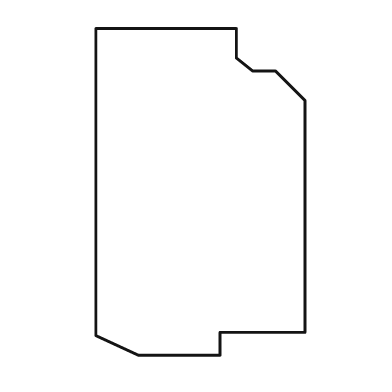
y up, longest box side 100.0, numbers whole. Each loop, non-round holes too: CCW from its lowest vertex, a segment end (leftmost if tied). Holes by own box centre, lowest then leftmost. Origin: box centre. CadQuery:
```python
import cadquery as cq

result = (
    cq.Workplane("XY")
    .moveTo(-19.0, -50.0)
    .lineTo(6.0, -50.0)
    .lineTo(6.0, -43.0)
    .lineTo(32.0, -43.0)
    .lineTo(32.0, 28.0)
    .lineTo(23.0, 37.0)
    .lineTo(16.0, 37.0)
    .lineTo(11.0, 41.0)
    .lineTo(11.0, 50.0)
    .lineTo(-32.0, 50.0)
    .lineTo(-32.0, -44.0)
    .close()
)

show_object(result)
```